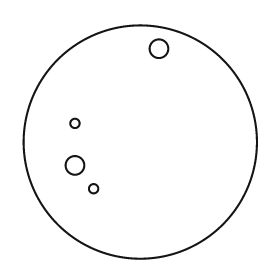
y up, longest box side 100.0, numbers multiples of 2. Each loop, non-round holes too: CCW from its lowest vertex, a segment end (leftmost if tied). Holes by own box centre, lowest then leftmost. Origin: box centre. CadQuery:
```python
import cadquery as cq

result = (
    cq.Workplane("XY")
    .moveTo(0.0, 0.0)
    .circle(50.0)
    .moveTo(-20.0, -20.0)
    .circle(2.0)
    .moveTo(-28.0, -10.0)
    .circle(4.0)
    .moveTo(-28.0, 8.0)
    .circle(2.0)
    .moveTo(8.0, 40.0)
    .circle(4.0)
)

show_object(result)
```